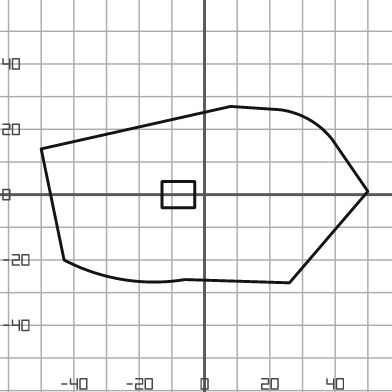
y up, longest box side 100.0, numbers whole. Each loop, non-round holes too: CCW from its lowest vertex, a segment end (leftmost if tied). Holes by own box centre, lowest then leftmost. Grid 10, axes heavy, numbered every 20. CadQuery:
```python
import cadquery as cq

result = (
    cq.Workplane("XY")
    .moveTo(26.0, -27.0)
    .lineTo(50.0, 1.0)
    .lineTo(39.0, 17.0)
    .threePointArc((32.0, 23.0), (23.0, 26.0))
    .lineTo(8.0, 27.0)
    .lineTo(-50.0, 14.0)
    .lineTo(-43.0, -20.0)
    .threePointArc((-25.0, -26.0), (-6.0, -26.0))
    .close()
    .moveTo(-13.0, -4.0)
    .lineTo(-3.0, -4.0)
    .lineTo(-3.0, 4.0)
    .lineTo(-13.0, 4.0)
    .close()
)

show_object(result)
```